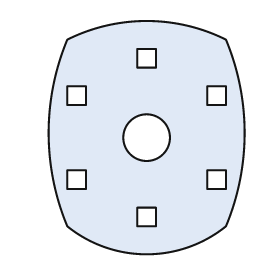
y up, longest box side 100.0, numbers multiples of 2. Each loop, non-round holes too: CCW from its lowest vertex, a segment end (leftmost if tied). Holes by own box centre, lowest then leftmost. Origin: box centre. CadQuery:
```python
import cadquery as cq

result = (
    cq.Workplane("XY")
    .moveTo(-34.0, -38.0)
    .threePointArc((0.0, -50.0), (34.0, -38.0))
    .threePointArc((42.0, 2.0), (34.0, 42.0))
    .threePointArc((0.0, 50.0), (-34.0, 42.0))
    .threePointArc((-42.0, 2.0), (-34.0, -38.0))
    .close()
    .moveTo(-4.0, -38.0)
    .lineTo(4.0, -38.0)
    .lineTo(4.0, -30.0)
    .lineTo(-4.0, -30.0)
    .close()
    .moveTo(-34.0, -22.0)
    .lineTo(-26.0, -22.0)
    .lineTo(-26.0, -14.0)
    .lineTo(-34.0, -14.0)
    .close()
    .moveTo(26.0, -22.0)
    .lineTo(34.0, -22.0)
    .lineTo(34.0, -14.0)
    .lineTo(26.0, -14.0)
    .close()
    .moveTo(0.0, 0.0)
    .circle(10.0)
    .moveTo(-34.0, 14.0)
    .lineTo(-26.0, 14.0)
    .lineTo(-26.0, 22.0)
    .lineTo(-34.0, 22.0)
    .close()
    .moveTo(26.0, 14.0)
    .lineTo(34.0, 14.0)
    .lineTo(34.0, 22.0)
    .lineTo(26.0, 22.0)
    .close()
    .moveTo(-4.0, 30.0)
    .lineTo(4.0, 30.0)
    .lineTo(4.0, 38.0)
    .lineTo(-4.0, 38.0)
    .close()
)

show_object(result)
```